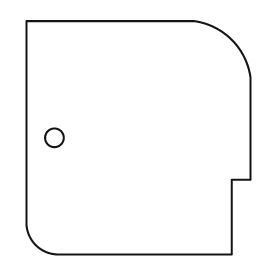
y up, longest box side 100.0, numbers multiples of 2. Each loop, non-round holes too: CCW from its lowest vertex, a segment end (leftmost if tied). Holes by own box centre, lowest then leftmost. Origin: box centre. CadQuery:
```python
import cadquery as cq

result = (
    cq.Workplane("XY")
    .moveTo(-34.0, -50.0)
    .lineTo(40.0, -50.0)
    .lineTo(40.0, -18.0)
    .lineTo(48.0, -18.0)
    .lineTo(48.0, 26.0)
    .threePointArc((40.0, 42.0), (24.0, 50.0))
    .lineTo(-48.0, 50.0)
    .lineTo(-48.0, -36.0)
    .threePointArc((-44.0, -46.0), (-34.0, -50.0))
    .close()
    .moveTo(-36.0, 0.0)
    .circle(4.0)
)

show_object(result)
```